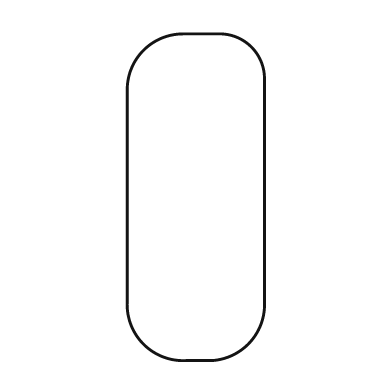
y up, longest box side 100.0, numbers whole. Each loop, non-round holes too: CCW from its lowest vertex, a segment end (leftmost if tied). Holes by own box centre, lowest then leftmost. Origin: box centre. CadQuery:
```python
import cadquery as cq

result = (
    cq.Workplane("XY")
    .moveTo(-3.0, -50.0)
    .lineTo(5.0, -50.0)
    .threePointArc((16.0, -45.0), (21.0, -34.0))
    .lineTo(21.0, 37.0)
    .threePointArc((17.0, 46.0), (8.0, 50.0))
    .lineTo(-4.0, 50.0)
    .threePointArc((-16.0, 45.0), (-21.0, 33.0))
    .lineTo(-21.0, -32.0)
    .threePointArc((-16.0, -45.0), (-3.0, -50.0))
    .close()
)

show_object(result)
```